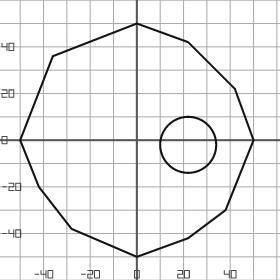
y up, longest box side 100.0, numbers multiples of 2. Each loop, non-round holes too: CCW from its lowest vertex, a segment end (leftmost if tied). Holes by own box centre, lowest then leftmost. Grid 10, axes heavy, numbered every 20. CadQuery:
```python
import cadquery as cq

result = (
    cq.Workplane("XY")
    .moveTo(0.0, -50.0)
    .lineTo(22.0, -42.0)
    .lineTo(38.0, -30.0)
    .lineTo(50.0, 0.0)
    .lineTo(42.0, 22.0)
    .lineTo(22.0, 42.0)
    .lineTo(0.0, 50.0)
    .lineTo(-36.0, 36.0)
    .lineTo(-50.0, 0.0)
    .lineTo(-42.0, -20.0)
    .lineTo(-28.0, -38.0)
    .close()
    .moveTo(22.0, -2.0)
    .circle(12.0)
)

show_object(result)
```